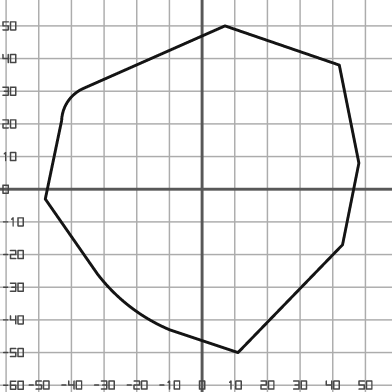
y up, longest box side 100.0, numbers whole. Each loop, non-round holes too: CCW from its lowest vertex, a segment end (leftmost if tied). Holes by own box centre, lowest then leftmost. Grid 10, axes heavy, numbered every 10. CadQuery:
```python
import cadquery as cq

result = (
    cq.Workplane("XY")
    .moveTo(11.0, -50.0)
    .lineTo(43.0, -17.0)
    .lineTo(48.0, 8.0)
    .lineTo(42.0, 38.0)
    .lineTo(7.0, 50.0)
    .lineTo(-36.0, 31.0)
    .threePointArc((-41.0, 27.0), (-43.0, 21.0))
    .lineTo(-48.0, -3.0)
    .lineTo(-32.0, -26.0)
    .threePointArc((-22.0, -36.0), (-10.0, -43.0))
    .close()
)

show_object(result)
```